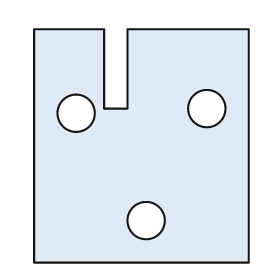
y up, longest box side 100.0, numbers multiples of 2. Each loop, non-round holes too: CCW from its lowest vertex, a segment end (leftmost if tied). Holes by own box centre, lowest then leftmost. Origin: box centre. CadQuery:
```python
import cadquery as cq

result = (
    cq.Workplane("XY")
    .moveTo(-46.0, -50.0)
    .lineTo(46.0, -50.0)
    .lineTo(46.0, 50.0)
    .lineTo(-6.0, 50.0)
    .lineTo(-6.0, 16.0)
    .lineTo(-16.0, 16.0)
    .lineTo(-16.0, 50.0)
    .lineTo(-46.0, 50.0)
    .close()
    .moveTo(2.0, -32.0)
    .circle(8.0)
    .moveTo(-28.0, 14.0)
    .circle(8.0)
    .moveTo(28.0, 16.0)
    .circle(8.0)
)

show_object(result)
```